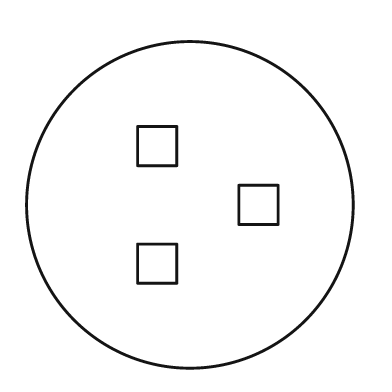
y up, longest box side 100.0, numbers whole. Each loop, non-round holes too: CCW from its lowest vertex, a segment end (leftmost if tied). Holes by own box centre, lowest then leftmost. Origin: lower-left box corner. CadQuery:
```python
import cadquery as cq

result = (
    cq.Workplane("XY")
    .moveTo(50.0, 50.0)
    .circle(50.0)
    .moveTo(34.0, 26.0)
    .lineTo(46.0, 26.0)
    .lineTo(46.0, 38.0)
    .lineTo(34.0, 38.0)
    .close()
    .moveTo(65.0, 44.0)
    .lineTo(77.0, 44.0)
    .lineTo(77.0, 56.0)
    .lineTo(65.0, 56.0)
    .close()
    .moveTo(34.0, 62.0)
    .lineTo(46.0, 62.0)
    .lineTo(46.0, 74.0)
    .lineTo(34.0, 74.0)
    .close()
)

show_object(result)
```